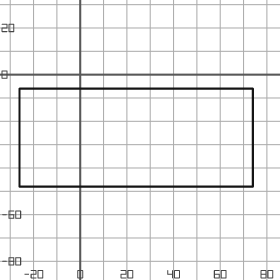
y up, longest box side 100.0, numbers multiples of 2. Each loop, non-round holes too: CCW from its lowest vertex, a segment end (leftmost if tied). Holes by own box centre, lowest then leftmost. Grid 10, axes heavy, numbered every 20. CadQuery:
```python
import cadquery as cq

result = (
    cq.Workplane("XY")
    .moveTo(-26.0, -48.0)
    .lineTo(74.0, -48.0)
    .lineTo(74.0, -6.0)
    .lineTo(-26.0, -6.0)
    .close()
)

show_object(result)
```